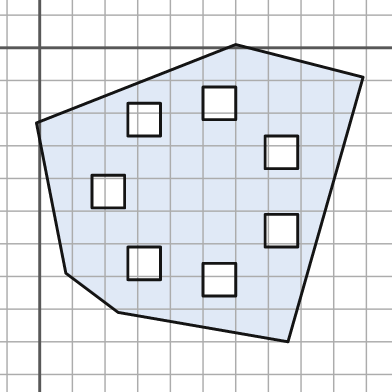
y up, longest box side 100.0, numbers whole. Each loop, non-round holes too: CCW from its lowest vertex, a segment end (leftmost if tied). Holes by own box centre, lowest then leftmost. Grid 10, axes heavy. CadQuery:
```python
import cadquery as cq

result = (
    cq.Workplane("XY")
    .moveTo(76.0, -90.0)
    .lineTo(99.0, -9.0)
    .lineTo(60.0, 1.0)
    .lineTo(-1.0, -23.0)
    .lineTo(8.0, -69.0)
    .lineTo(24.0, -81.0)
    .close()
    .moveTo(50.0, -76.0)
    .lineTo(60.0, -76.0)
    .lineTo(60.0, -66.0)
    .lineTo(50.0, -66.0)
    .close()
    .moveTo(27.0, -71.0)
    .lineTo(37.0, -71.0)
    .lineTo(37.0, -61.0)
    .lineTo(27.0, -61.0)
    .close()
    .moveTo(69.0, -61.0)
    .lineTo(79.0, -61.0)
    .lineTo(79.0, -51.0)
    .lineTo(69.0, -51.0)
    .close()
    .moveTo(16.0, -49.0)
    .lineTo(26.0, -49.0)
    .lineTo(26.0, -39.0)
    .lineTo(16.0, -39.0)
    .close()
    .moveTo(69.0, -37.0)
    .lineTo(79.0, -37.0)
    .lineTo(79.0, -27.0)
    .lineTo(69.0, -27.0)
    .close()
    .moveTo(27.0, -27.0)
    .lineTo(37.0, -27.0)
    .lineTo(37.0, -17.0)
    .lineTo(27.0, -17.0)
    .close()
    .moveTo(50.0, -22.0)
    .lineTo(60.0, -22.0)
    .lineTo(60.0, -12.0)
    .lineTo(50.0, -12.0)
    .close()
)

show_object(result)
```